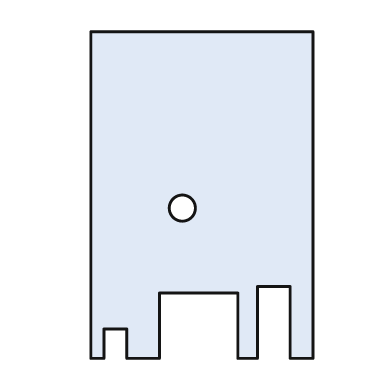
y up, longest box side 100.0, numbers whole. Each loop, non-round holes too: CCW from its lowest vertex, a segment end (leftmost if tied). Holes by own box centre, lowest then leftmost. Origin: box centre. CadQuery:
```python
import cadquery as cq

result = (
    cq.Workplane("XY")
    .moveTo(-34.0, -50.0)
    .lineTo(-30.0, -50.0)
    .lineTo(-30.0, -41.0)
    .lineTo(-23.0, -41.0)
    .lineTo(-23.0, -50.0)
    .lineTo(-13.0, -50.0)
    .lineTo(-13.0, -30.0)
    .lineTo(11.0, -30.0)
    .lineTo(11.0, -50.0)
    .lineTo(17.0, -50.0)
    .lineTo(17.0, -28.0)
    .lineTo(27.0, -28.0)
    .lineTo(27.0, -50.0)
    .lineTo(34.0, -50.0)
    .lineTo(34.0, 50.0)
    .lineTo(-34.0, 50.0)
    .close()
    .moveTo(-6.0, -4.0)
    .circle(4.0)
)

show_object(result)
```